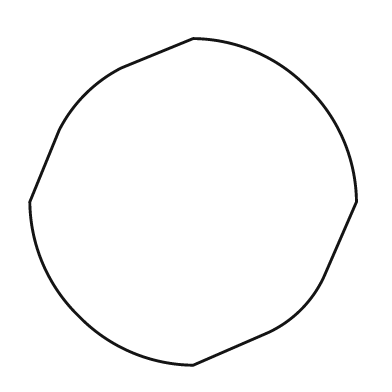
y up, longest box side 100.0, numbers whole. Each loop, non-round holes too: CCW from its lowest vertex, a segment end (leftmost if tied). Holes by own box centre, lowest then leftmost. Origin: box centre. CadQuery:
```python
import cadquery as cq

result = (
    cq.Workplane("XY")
    .moveTo(0.0, -50.0)
    .lineTo(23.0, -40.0)
    .threePointArc((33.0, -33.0), (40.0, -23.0))
    .lineTo(50.0, 0.0)
    .threePointArc((46.0, 19.0), (35.0, 35.0))
    .threePointArc((19.0, 46.0), (0.0, 50.0))
    .lineTo(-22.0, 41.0)
    .threePointArc((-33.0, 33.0), (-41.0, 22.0))
    .lineTo(-50.0, 0.0)
    .threePointArc((-46.0, -19.0), (-35.0, -35.0))
    .threePointArc((-19.0, -46.0), (0.0, -50.0))
    .close()
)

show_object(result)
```